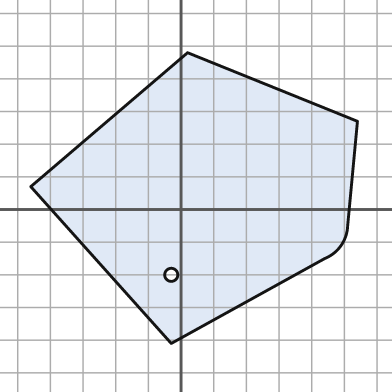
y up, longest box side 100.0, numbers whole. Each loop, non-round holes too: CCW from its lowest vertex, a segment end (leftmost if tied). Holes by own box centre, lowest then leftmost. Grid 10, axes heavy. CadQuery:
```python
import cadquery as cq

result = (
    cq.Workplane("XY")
    .moveTo(-3.0, -41.0)
    .lineTo(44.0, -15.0)
    .threePointArc((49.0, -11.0), (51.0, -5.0))
    .lineTo(54.0, 27.0)
    .lineTo(2.0, 48.0)
    .lineTo(-46.0, 7.0)
    .close()
    .moveTo(-3.0, -20.0)
    .circle(2.0)
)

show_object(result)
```